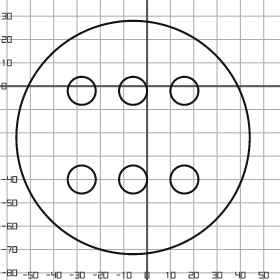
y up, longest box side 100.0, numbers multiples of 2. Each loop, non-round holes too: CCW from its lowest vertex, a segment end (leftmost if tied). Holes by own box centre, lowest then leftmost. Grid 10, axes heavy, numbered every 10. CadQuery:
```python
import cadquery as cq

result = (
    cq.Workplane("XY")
    .moveTo(-6.0, -22.0)
    .circle(50.0)
    .moveTo(-28.0, -40.0)
    .circle(6.0)
    .moveTo(-6.0, -40.0)
    .circle(6.0)
    .moveTo(16.0, -40.0)
    .circle(6.0)
    .moveTo(-28.0, -2.0)
    .circle(6.0)
    .moveTo(-6.0, -2.0)
    .circle(6.0)
    .moveTo(16.0, -2.0)
    .circle(6.0)
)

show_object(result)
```